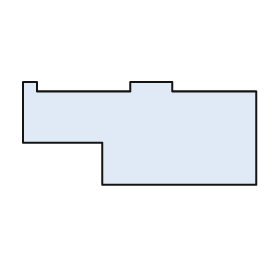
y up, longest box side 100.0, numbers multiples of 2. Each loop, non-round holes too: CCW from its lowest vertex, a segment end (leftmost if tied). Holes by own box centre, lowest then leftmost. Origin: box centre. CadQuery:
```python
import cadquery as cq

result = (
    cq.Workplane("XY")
    .moveTo(-16.0, -22.0)
    .lineTo(50.0, -22.0)
    .lineTo(50.0, 18.0)
    .lineTo(14.0, 18.0)
    .lineTo(14.0, 22.0)
    .lineTo(-4.0, 22.0)
    .lineTo(-4.0, 18.0)
    .lineTo(-44.0, 18.0)
    .lineTo(-44.0, 22.0)
    .lineTo(-50.0, 22.0)
    .lineTo(-50.0, -4.0)
    .lineTo(-16.0, -4.0)
    .close()
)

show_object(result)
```